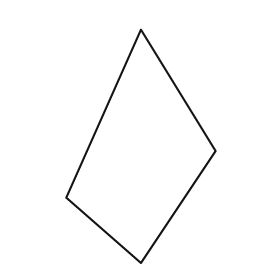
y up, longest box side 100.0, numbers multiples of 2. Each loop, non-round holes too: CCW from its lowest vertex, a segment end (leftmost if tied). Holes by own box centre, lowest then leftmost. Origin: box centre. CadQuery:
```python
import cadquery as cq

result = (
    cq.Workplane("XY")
    .moveTo(0.0, -50.0)
    .lineTo(32.0, -2.0)
    .lineTo(0.0, 50.0)
    .lineTo(-32.0, -22.0)
    .close()
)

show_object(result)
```